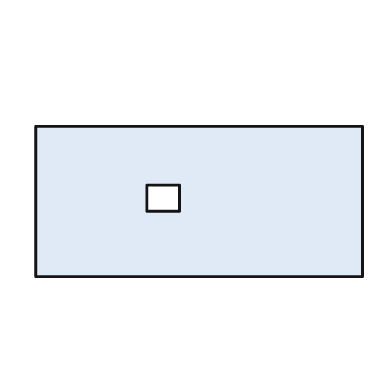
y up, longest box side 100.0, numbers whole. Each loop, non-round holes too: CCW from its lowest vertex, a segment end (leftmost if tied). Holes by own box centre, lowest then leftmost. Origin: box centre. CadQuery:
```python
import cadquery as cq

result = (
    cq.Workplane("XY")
    .moveTo(-50.0, -23.0)
    .lineTo(50.0, -23.0)
    .lineTo(50.0, 23.0)
    .lineTo(-50.0, 23.0)
    .close()
    .moveTo(-16.0, -3.0)
    .lineTo(-6.0, -3.0)
    .lineTo(-6.0, 5.0)
    .lineTo(-16.0, 5.0)
    .close()
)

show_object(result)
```